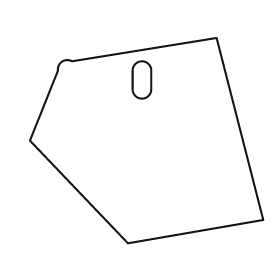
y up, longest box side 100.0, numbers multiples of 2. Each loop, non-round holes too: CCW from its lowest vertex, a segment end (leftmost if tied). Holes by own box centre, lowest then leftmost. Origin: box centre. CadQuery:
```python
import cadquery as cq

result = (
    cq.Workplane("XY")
    .moveTo(-8.0, -44.0)
    .lineTo(50.0, -34.0)
    .lineTo(30.0, 44.0)
    .lineTo(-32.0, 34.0)
    .threePointArc((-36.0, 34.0), (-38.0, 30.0))
    .lineTo(-50.0, 0.0)
    .close()
    .moveTo(-6.0, 22.0)
    .threePointArc((-2.0, 18.0), (2.0, 22.0))
    .lineTo(2.0, 30.0)
    .threePointArc((-2.0, 34.0), (-6.0, 30.0))
    .close()
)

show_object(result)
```